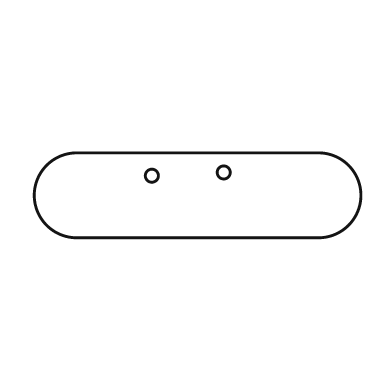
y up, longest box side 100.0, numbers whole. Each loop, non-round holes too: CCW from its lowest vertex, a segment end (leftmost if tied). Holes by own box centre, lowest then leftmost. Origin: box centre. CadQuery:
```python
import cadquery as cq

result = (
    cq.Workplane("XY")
    .moveTo(-37.0, -13.0)
    .lineTo(37.0, -13.0)
    .threePointArc((50.0, 0.0), (37.0, 13.0))
    .lineTo(-37.0, 13.0)
    .threePointArc((-50.0, 0.0), (-37.0, -13.0))
    .close()
    .moveTo(-14.0, 6.0)
    .circle(2.0)
    .moveTo(8.0, 7.0)
    .circle(2.0)
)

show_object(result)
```